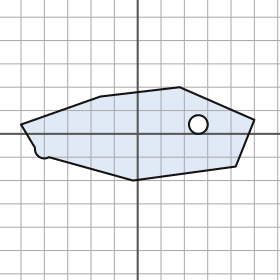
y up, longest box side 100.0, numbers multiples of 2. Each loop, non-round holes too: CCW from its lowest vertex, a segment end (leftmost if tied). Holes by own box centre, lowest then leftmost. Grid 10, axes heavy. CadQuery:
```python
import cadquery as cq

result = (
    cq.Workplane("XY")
    .moveTo(-2.0, -20.0)
    .lineTo(42.0, -14.0)
    .lineTo(50.0, 6.0)
    .lineTo(18.0, 20.0)
    .lineTo(-16.0, 16.0)
    .lineTo(-50.0, 4.0)
    .lineTo(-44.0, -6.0)
    .threePointArc((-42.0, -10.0), (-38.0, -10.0))
    .close()
    .moveTo(26.0, 4.0)
    .circle(4.0)
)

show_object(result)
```